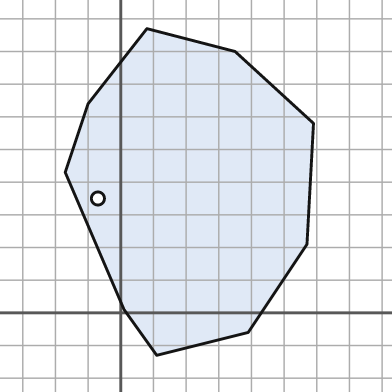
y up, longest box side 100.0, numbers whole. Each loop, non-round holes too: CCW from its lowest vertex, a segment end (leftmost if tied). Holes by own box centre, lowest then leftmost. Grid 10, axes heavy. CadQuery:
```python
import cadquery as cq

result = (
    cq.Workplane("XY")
    .moveTo(11.0, -13.0)
    .lineTo(39.0, -6.0)
    .lineTo(57.0, 21.0)
    .lineTo(59.0, 58.0)
    .lineTo(35.0, 80.0)
    .lineTo(8.0, 87.0)
    .lineTo(-10.0, 64.0)
    .lineTo(-17.0, 43.0)
    .lineTo(1.0, 1.0)
    .close()
    .moveTo(-7.0, 35.0)
    .circle(2.0)
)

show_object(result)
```